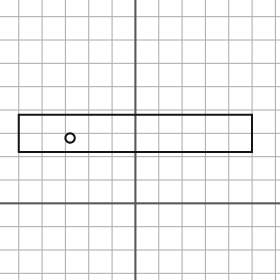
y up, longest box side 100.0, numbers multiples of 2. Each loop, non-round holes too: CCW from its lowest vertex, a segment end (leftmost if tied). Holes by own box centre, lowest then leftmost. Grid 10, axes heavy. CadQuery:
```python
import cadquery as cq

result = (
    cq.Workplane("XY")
    .moveTo(-50.0, 22.0)
    .lineTo(50.0, 22.0)
    .lineTo(50.0, 38.0)
    .lineTo(-50.0, 38.0)
    .close()
    .moveTo(-28.0, 28.0)
    .circle(2.0)
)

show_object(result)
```